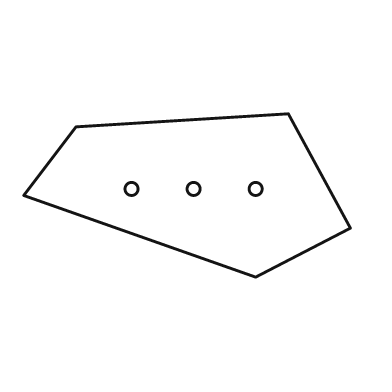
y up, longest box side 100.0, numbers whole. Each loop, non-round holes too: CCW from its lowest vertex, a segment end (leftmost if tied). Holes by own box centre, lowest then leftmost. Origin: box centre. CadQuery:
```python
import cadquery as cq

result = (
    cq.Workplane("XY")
    .moveTo(21.0, -25.0)
    .lineTo(50.0, -10.0)
    .lineTo(31.0, 25.0)
    .lineTo(-34.0, 21.0)
    .lineTo(-50.0, 0.0)
    .close()
    .moveTo(-17.0, 2.0)
    .circle(2.0)
    .moveTo(2.0, 2.0)
    .circle(2.0)
    .moveTo(21.0, 2.0)
    .circle(2.0)
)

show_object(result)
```